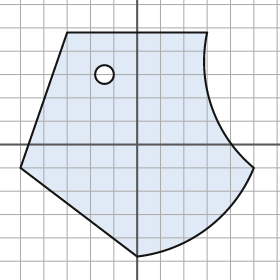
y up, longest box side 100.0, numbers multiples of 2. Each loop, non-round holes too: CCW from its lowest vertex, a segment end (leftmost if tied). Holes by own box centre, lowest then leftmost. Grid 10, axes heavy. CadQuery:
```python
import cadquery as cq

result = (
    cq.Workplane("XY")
    .moveTo(0.0, -48.0)
    .threePointArc((30.0, -36.0), (50.0, -10.0))
    .threePointArc((32.0, 16.0), (30.0, 48.0))
    .lineTo(-30.0, 48.0)
    .lineTo(-50.0, -10.0)
    .close()
    .moveTo(-14.0, 30.0)
    .circle(4.0)
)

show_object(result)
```